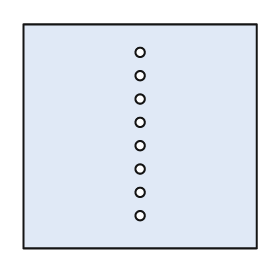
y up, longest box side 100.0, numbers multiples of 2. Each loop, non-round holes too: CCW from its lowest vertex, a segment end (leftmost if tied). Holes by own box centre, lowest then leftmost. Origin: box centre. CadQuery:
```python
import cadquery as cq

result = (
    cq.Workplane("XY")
    .moveTo(-50.0, -48.0)
    .lineTo(50.0, -48.0)
    .lineTo(50.0, 48.0)
    .lineTo(-50.0, 48.0)
    .close()
    .moveTo(0.0, -34.0)
    .circle(2.0)
    .moveTo(0.0, -24.0)
    .circle(2.0)
    .moveTo(0.0, -14.0)
    .circle(2.0)
    .moveTo(0.0, -4.0)
    .circle(2.0)
    .moveTo(0.0, 6.0)
    .circle(2.0)
    .moveTo(0.0, 16.0)
    .circle(2.0)
    .moveTo(0.0, 26.0)
    .circle(2.0)
    .moveTo(0.0, 36.0)
    .circle(2.0)
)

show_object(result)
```